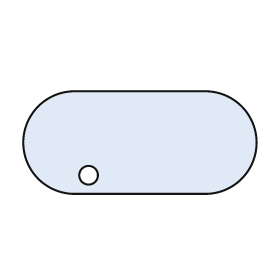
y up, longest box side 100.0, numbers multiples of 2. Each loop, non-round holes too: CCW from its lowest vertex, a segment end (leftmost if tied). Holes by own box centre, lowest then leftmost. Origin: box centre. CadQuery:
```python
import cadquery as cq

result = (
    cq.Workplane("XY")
    .moveTo(-28.0, -22.0)
    .lineTo(28.0, -22.0)
    .threePointArc((50.0, 0.0), (28.0, 22.0))
    .lineTo(-28.0, 22.0)
    .threePointArc((-50.0, 0.0), (-28.0, -22.0))
    .close()
    .moveTo(-22.0, -14.0)
    .circle(4.0)
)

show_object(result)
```